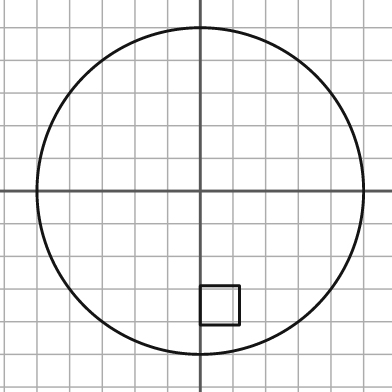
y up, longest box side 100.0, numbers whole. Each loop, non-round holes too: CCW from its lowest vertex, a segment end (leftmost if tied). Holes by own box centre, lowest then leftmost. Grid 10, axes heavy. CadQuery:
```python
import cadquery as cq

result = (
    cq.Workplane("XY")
    .moveTo(0.0, 0.0)
    .circle(50.0)
    .moveTo(0.0, -41.0)
    .lineTo(12.0, -41.0)
    .lineTo(12.0, -29.0)
    .lineTo(0.0, -29.0)
    .close()
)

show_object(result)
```